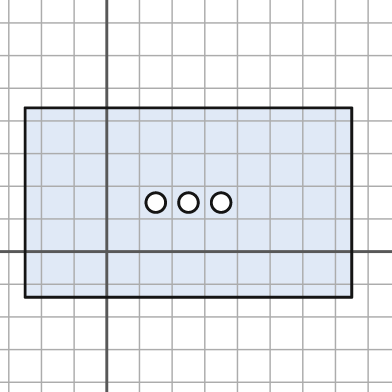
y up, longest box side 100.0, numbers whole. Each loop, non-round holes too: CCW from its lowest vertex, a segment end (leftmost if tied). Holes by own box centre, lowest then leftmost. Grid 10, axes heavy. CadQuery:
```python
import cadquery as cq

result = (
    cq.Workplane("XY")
    .moveTo(-25.0, -14.0)
    .lineTo(75.0, -14.0)
    .lineTo(75.0, 44.0)
    .lineTo(-25.0, 44.0)
    .close()
    .moveTo(15.0, 15.0)
    .circle(3.0)
    .moveTo(25.0, 15.0)
    .circle(3.0)
    .moveTo(35.0, 15.0)
    .circle(3.0)
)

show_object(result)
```